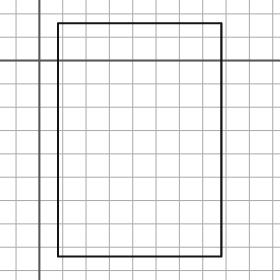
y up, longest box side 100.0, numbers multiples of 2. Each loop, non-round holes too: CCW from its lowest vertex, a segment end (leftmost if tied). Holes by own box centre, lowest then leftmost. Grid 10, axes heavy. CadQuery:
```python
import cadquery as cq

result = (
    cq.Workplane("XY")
    .moveTo(8.0, -84.0)
    .lineTo(78.0, -84.0)
    .lineTo(78.0, 16.0)
    .lineTo(8.0, 16.0)
    .close()
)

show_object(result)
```